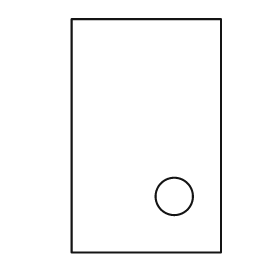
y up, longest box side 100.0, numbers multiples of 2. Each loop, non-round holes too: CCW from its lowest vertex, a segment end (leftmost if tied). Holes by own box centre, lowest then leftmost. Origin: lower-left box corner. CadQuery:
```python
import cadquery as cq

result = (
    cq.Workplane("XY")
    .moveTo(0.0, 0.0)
    .lineTo(64.0, 0.0)
    .lineTo(64.0, 100.0)
    .lineTo(0.0, 100.0)
    .close()
    .moveTo(44.0, 24.0)
    .circle(8.0)
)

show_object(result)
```